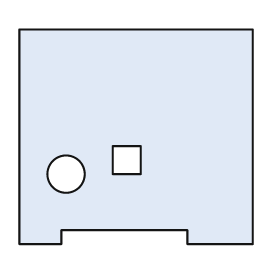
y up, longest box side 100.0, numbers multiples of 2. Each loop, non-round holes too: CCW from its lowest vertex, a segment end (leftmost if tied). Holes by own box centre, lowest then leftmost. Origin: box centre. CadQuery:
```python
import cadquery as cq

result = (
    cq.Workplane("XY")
    .moveTo(-50.0, -46.0)
    .lineTo(-32.0, -46.0)
    .lineTo(-32.0, -40.0)
    .lineTo(22.0, -40.0)
    .lineTo(22.0, -46.0)
    .lineTo(50.0, -46.0)
    .lineTo(50.0, 46.0)
    .lineTo(-50.0, 46.0)
    .close()
    .moveTo(-30.0, -16.0)
    .circle(8.0)
    .moveTo(-10.0, -16.0)
    .lineTo(2.0, -16.0)
    .lineTo(2.0, -4.0)
    .lineTo(-10.0, -4.0)
    .close()
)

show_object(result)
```